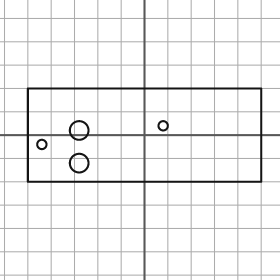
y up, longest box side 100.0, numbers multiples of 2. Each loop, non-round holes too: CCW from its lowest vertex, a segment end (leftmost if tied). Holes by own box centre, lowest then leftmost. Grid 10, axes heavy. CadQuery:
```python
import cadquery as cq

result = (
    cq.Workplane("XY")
    .moveTo(-50.0, -20.0)
    .lineTo(50.0, -20.0)
    .lineTo(50.0, 20.0)
    .lineTo(-50.0, 20.0)
    .close()
    .moveTo(-28.0, -12.0)
    .circle(4.0)
    .moveTo(-44.0, -4.0)
    .circle(2.0)
    .moveTo(-28.0, 2.0)
    .circle(4.0)
    .moveTo(8.0, 4.0)
    .circle(2.0)
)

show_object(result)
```